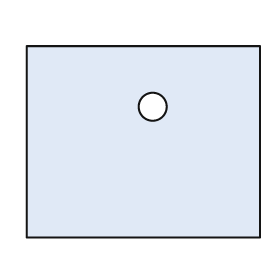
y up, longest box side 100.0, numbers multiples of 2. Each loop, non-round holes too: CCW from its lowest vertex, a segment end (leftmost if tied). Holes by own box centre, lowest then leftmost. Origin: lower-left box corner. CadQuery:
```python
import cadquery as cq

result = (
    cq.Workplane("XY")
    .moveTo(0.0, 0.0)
    .lineTo(100.0, 0.0)
    .lineTo(100.0, 82.0)
    .lineTo(0.0, 82.0)
    .close()
    .moveTo(54.0, 56.0)
    .circle(6.0)
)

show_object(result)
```